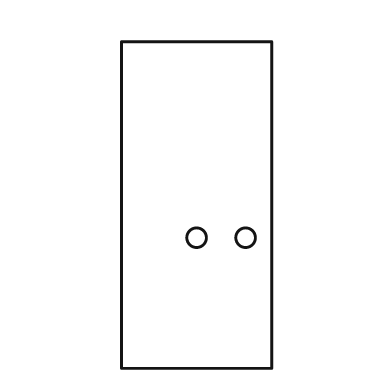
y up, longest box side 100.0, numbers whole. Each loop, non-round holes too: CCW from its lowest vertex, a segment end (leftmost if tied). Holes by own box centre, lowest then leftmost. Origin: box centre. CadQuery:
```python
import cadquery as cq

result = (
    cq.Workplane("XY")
    .moveTo(-23.0, -50.0)
    .lineTo(23.0, -50.0)
    .lineTo(23.0, 50.0)
    .lineTo(-23.0, 50.0)
    .close()
    .moveTo(0.0, -10.0)
    .circle(3.0)
    .moveTo(15.0, -10.0)
    .circle(3.0)
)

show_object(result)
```